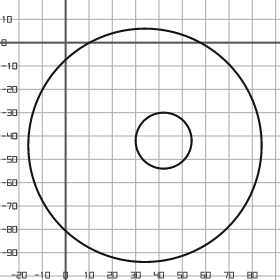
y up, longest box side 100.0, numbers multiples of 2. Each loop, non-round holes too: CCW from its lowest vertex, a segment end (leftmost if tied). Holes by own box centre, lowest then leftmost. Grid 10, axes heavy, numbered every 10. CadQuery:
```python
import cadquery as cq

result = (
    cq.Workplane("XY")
    .moveTo(34.0, -44.0)
    .circle(50.0)
    .moveTo(42.0, -42.0)
    .circle(12.0)
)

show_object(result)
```